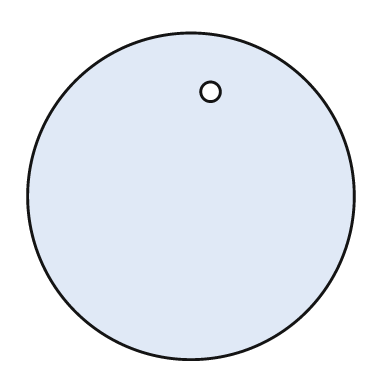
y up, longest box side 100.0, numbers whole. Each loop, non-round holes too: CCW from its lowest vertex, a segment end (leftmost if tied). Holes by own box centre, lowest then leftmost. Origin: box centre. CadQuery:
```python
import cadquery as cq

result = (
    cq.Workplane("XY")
    .moveTo(0.0, 0.0)
    .circle(50.0)
    .moveTo(6.0, 32.0)
    .circle(3.0)
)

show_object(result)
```